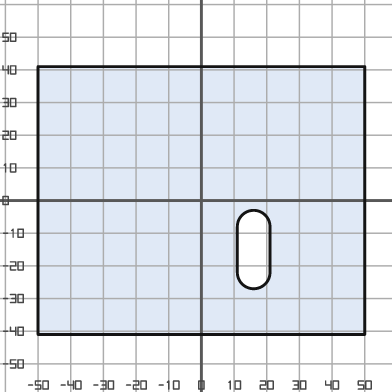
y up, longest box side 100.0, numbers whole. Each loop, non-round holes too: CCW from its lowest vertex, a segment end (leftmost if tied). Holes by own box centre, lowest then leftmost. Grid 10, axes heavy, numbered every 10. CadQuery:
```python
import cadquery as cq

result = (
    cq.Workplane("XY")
    .moveTo(-50.0, -41.0)
    .lineTo(50.0, -41.0)
    .lineTo(50.0, 41.0)
    .lineTo(-50.0, 41.0)
    .close()
    .moveTo(11.0, -22.0)
    .threePointArc((16.0, -27.0), (21.0, -22.0))
    .lineTo(21.0, -8.0)
    .threePointArc((16.0, -3.0), (11.0, -8.0))
    .close()
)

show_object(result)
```